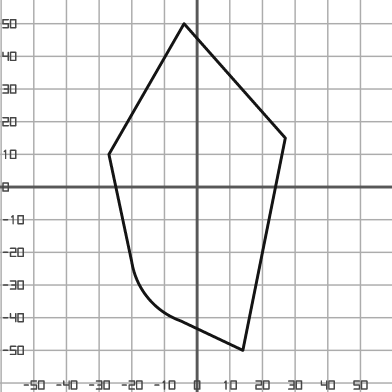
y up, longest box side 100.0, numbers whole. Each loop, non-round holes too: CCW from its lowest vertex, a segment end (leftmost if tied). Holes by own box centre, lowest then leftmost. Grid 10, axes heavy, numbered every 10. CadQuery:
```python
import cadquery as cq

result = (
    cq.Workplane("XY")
    .moveTo(14.0, -50.0)
    .lineTo(27.0, 15.0)
    .lineTo(-4.0, 50.0)
    .lineTo(-27.0, 10.0)
    .lineTo(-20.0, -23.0)
    .threePointArc((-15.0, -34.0), (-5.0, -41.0))
    .close()
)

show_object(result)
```